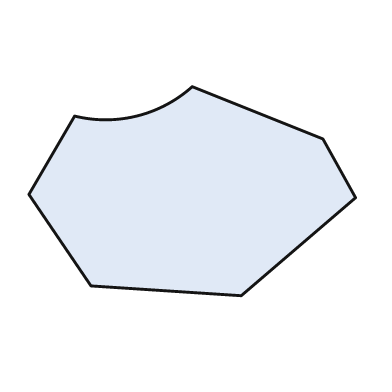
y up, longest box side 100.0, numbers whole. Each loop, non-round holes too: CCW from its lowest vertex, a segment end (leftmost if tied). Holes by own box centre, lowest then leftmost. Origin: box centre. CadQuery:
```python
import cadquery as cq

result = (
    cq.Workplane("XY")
    .moveTo(15.0, -32.0)
    .lineTo(50.0, -2.0)
    .lineTo(40.0, 16.0)
    .lineTo(0.0, 32.0)
    .threePointArc((-17.0, 23.0), (-36.0, 23.0))
    .lineTo(-50.0, -1.0)
    .lineTo(-31.0, -29.0)
    .close()
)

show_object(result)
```